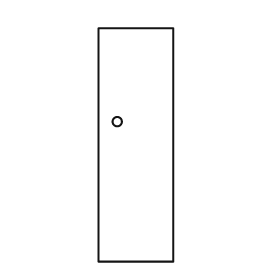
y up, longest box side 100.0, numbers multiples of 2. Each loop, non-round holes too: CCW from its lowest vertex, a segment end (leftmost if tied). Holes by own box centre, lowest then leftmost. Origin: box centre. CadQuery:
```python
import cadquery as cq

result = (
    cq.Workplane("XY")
    .moveTo(-16.0, -50.0)
    .lineTo(16.0, -50.0)
    .lineTo(16.0, 50.0)
    .lineTo(-16.0, 50.0)
    .close()
    .moveTo(-8.0, 10.0)
    .circle(2.0)
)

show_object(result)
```